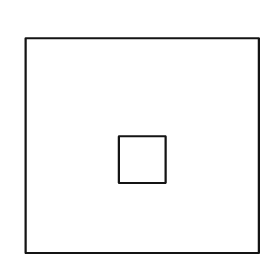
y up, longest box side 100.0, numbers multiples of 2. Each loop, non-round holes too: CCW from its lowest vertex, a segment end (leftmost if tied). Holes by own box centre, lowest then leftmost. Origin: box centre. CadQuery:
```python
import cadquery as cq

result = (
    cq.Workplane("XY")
    .moveTo(-50.0, -46.0)
    .lineTo(50.0, -46.0)
    .lineTo(50.0, 46.0)
    .lineTo(-50.0, 46.0)
    .close()
    .moveTo(-10.0, -16.0)
    .lineTo(10.0, -16.0)
    .lineTo(10.0, 4.0)
    .lineTo(-10.0, 4.0)
    .close()
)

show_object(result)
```